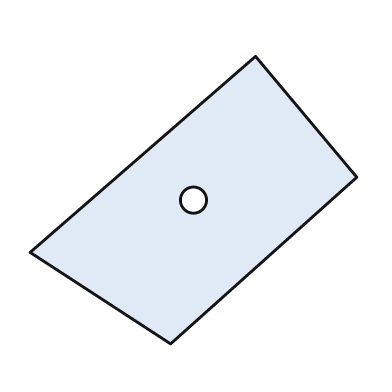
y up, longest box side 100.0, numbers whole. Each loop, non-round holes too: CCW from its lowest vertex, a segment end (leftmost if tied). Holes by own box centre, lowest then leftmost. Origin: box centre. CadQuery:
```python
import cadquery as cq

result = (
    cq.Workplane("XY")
    .moveTo(-7.0, -44.0)
    .lineTo(50.0, 7.0)
    .lineTo(19.0, 44.0)
    .lineTo(-50.0, -16.0)
    .close()
    .moveTo(0.0, 0.0)
    .circle(4.0)
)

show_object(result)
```